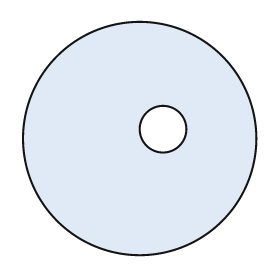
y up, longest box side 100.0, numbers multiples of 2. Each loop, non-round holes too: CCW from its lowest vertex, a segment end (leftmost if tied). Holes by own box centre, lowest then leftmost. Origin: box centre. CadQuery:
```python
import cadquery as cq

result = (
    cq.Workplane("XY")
    .moveTo(0.0, 0.0)
    .circle(50.0)
    .moveTo(10.0, 4.0)
    .circle(10.0)
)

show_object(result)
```